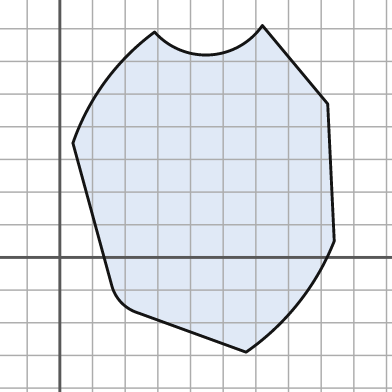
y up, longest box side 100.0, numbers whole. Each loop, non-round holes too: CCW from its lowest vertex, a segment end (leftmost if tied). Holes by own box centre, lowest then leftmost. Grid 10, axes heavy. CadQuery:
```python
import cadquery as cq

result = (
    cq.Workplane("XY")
    .moveTo(57.0, -29.0)
    .threePointArc((73.0, -14.0), (84.0, 5.0))
    .lineTo(82.0, 47.0)
    .lineTo(62.0, 71.0)
    .threePointArc((46.0, 62.0), (29.0, 69.0))
    .threePointArc((14.0, 54.0), (4.0, 35.0))
    .lineTo(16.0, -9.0)
    .threePointArc((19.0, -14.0), (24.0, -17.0))
    .close()
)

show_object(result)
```